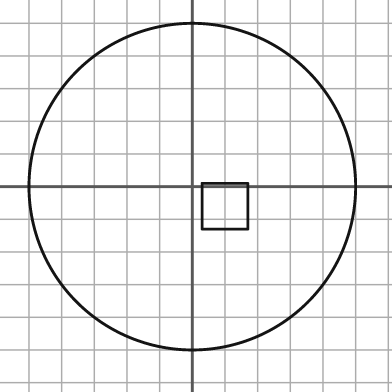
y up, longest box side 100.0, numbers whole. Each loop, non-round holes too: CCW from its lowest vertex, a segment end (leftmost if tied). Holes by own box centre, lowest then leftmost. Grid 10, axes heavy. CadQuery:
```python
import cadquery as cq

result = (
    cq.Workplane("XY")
    .moveTo(0.0, 0.0)
    .circle(50.0)
    .moveTo(3.0, -13.0)
    .lineTo(17.0, -13.0)
    .lineTo(17.0, 1.0)
    .lineTo(3.0, 1.0)
    .close()
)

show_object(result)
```